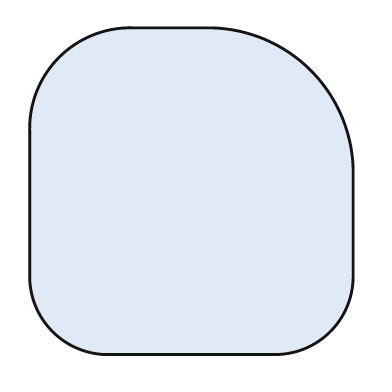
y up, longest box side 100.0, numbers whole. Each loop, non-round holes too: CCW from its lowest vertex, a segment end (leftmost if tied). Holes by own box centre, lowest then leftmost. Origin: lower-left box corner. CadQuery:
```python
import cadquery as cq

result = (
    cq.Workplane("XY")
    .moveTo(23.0, 0.0)
    .lineTo(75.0, 0.0)
    .threePointArc((92.0, 7.0), (99.0, 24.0))
    .lineTo(99.0, 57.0)
    .threePointArc((86.0, 87.0), (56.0, 100.0))
    .lineTo(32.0, 100.0)
    .threePointArc((9.0, 91.0), (0.0, 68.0))
    .lineTo(0.0, 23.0)
    .threePointArc((7.0, 7.0), (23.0, 0.0))
    .close()
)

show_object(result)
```